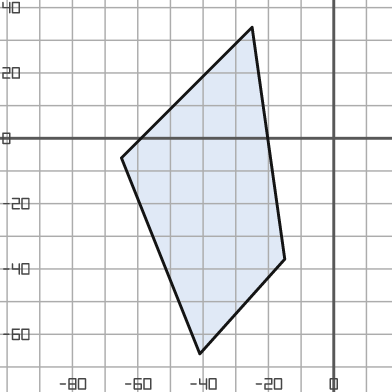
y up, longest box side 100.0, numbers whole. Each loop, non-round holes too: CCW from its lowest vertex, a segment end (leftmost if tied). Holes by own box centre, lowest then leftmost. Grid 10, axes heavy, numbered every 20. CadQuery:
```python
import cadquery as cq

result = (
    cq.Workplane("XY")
    .moveTo(-41.0, -66.0)
    .lineTo(-15.0, -37.0)
    .lineTo(-25.0, 34.0)
    .lineTo(-65.0, -6.0)
    .close()
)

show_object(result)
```